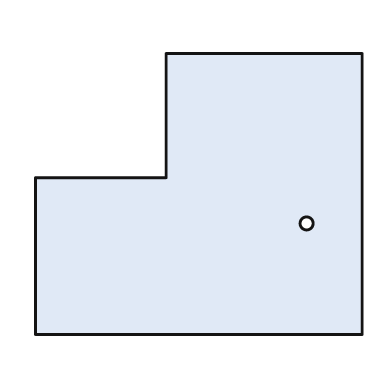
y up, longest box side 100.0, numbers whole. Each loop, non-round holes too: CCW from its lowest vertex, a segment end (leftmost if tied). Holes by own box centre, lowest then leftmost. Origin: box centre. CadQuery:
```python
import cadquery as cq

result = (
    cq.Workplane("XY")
    .moveTo(-50.0, -43.0)
    .lineTo(50.0, -43.0)
    .lineTo(50.0, 43.0)
    .lineTo(-10.0, 43.0)
    .lineTo(-10.0, 5.0)
    .lineTo(-50.0, 5.0)
    .close()
    .moveTo(33.0, -9.0)
    .circle(2.0)
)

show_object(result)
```